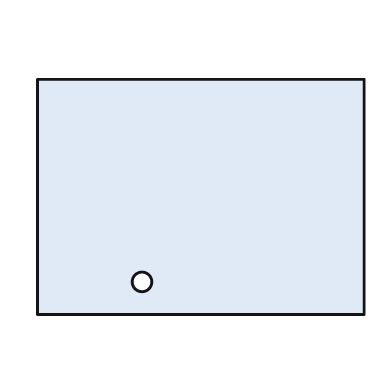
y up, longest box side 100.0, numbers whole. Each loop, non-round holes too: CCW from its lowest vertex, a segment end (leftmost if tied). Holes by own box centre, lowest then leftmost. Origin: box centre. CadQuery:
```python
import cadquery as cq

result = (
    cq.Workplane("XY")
    .moveTo(-50.0, -36.0)
    .lineTo(50.0, -36.0)
    .lineTo(50.0, 36.0)
    .lineTo(-50.0, 36.0)
    .close()
    .moveTo(-18.0, -26.0)
    .circle(3.0)
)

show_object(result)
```